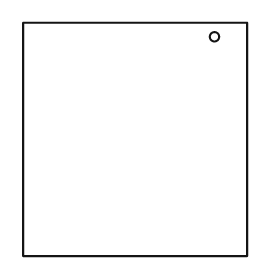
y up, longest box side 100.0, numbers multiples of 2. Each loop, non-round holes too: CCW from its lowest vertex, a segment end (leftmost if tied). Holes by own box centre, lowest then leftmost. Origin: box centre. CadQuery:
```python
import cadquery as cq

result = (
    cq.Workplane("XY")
    .moveTo(-48.0, -50.0)
    .lineTo(48.0, -50.0)
    .lineTo(48.0, 50.0)
    .lineTo(-48.0, 50.0)
    .close()
    .moveTo(34.0, 44.0)
    .circle(2.0)
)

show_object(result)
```